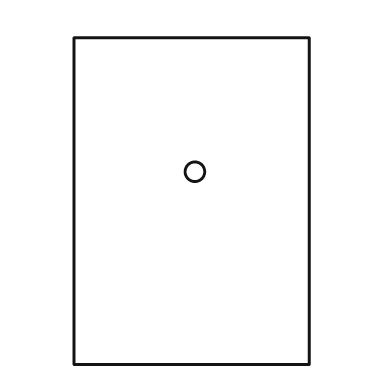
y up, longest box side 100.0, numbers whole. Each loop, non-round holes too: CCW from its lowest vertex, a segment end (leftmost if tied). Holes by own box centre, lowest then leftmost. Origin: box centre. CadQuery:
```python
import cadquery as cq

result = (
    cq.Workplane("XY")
    .moveTo(-36.0, -50.0)
    .lineTo(36.0, -50.0)
    .lineTo(36.0, 50.0)
    .lineTo(-36.0, 50.0)
    .close()
    .moveTo(1.0, 9.0)
    .circle(3.0)
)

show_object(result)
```